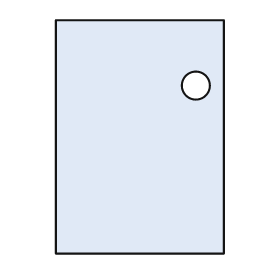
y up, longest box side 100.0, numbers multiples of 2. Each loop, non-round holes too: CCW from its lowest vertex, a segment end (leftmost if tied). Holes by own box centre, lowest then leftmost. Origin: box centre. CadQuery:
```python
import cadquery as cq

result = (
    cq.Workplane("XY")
    .moveTo(-36.0, -50.0)
    .lineTo(36.0, -50.0)
    .lineTo(36.0, 50.0)
    .lineTo(-36.0, 50.0)
    .close()
    .moveTo(24.0, 22.0)
    .circle(6.0)
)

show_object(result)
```